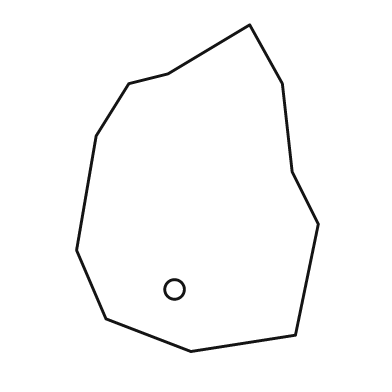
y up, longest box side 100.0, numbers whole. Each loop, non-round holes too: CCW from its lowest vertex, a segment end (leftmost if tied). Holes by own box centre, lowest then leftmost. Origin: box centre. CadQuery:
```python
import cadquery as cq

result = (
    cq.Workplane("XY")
    .moveTo(-2.0, -50.0)
    .lineTo(30.0, -45.0)
    .lineTo(37.0, -11.0)
    .lineTo(29.0, 5.0)
    .lineTo(26.0, 32.0)
    .lineTo(16.0, 50.0)
    .lineTo(-9.0, 35.0)
    .lineTo(-21.0, 32.0)
    .lineTo(-31.0, 16.0)
    .lineTo(-37.0, -19.0)
    .lineTo(-28.0, -40.0)
    .close()
    .moveTo(-7.0, -31.0)
    .circle(3.0)
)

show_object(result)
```